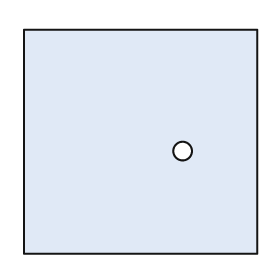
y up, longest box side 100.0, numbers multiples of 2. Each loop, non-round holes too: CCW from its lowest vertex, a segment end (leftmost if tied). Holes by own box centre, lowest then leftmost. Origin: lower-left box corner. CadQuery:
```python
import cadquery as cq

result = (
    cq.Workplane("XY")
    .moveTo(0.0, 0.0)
    .lineTo(100.0, 0.0)
    .lineTo(100.0, 96.0)
    .lineTo(0.0, 96.0)
    .close()
    .moveTo(68.0, 44.0)
    .circle(4.0)
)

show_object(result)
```